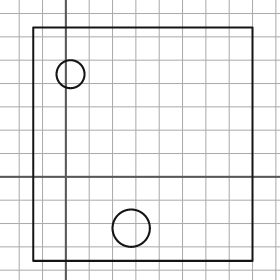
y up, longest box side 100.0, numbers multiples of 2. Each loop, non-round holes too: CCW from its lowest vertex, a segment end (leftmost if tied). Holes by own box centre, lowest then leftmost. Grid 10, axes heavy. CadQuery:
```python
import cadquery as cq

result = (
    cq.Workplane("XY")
    .moveTo(-14.0, -36.0)
    .lineTo(80.0, -36.0)
    .lineTo(80.0, 64.0)
    .lineTo(-14.0, 64.0)
    .close()
    .moveTo(28.0, -22.0)
    .circle(8.0)
    .moveTo(2.0, 44.0)
    .circle(6.0)
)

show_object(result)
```